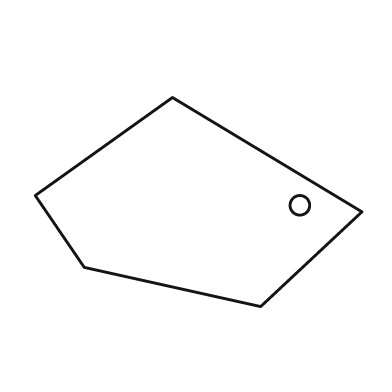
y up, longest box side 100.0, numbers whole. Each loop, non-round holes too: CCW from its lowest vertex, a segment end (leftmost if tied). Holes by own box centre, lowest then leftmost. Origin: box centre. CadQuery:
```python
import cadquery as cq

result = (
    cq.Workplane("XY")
    .moveTo(19.0, -32.0)
    .lineTo(50.0, -3.0)
    .lineTo(-8.0, 32.0)
    .lineTo(-50.0, 2.0)
    .lineTo(-35.0, -20.0)
    .close()
    .moveTo(31.0, -1.0)
    .circle(3.0)
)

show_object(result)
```